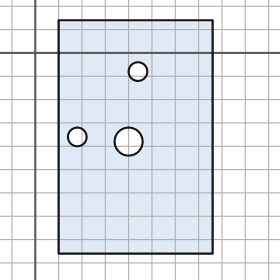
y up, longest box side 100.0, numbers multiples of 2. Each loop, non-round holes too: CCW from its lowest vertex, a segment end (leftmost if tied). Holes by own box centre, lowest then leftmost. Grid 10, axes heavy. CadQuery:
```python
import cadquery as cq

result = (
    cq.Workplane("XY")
    .moveTo(10.0, -86.0)
    .lineTo(76.0, -86.0)
    .lineTo(76.0, 14.0)
    .lineTo(10.0, 14.0)
    .close()
    .moveTo(40.0, -38.0)
    .circle(6.0)
    .moveTo(18.0, -36.0)
    .circle(4.0)
    .moveTo(44.0, -8.0)
    .circle(4.0)
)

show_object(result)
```